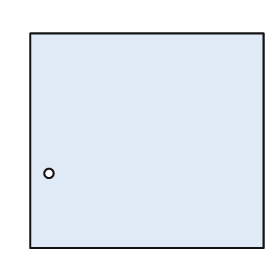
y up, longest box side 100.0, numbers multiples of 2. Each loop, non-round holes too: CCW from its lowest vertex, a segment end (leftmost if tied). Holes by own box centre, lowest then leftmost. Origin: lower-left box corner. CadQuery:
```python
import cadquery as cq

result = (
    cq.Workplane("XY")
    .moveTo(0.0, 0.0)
    .lineTo(100.0, 0.0)
    .lineTo(100.0, 92.0)
    .lineTo(0.0, 92.0)
    .close()
    .moveTo(8.0, 32.0)
    .circle(2.0)
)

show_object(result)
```